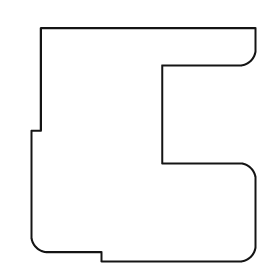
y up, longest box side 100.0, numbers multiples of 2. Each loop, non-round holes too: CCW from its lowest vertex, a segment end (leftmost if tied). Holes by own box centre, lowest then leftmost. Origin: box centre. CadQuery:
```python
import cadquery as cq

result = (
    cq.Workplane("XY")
    .moveTo(-18.0, -50.0)
    .lineTo(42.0, -50.0)
    .threePointArc((46.0, -48.0), (48.0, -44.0))
    .lineTo(48.0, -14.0)
    .threePointArc((46.0, -10.0), (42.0, -8.0))
    .lineTo(8.0, -8.0)
    .lineTo(8.0, 34.0)
    .lineTo(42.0, 34.0)
    .threePointArc((46.0, 36.0), (48.0, 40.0))
    .lineTo(48.0, 50.0)
    .lineTo(-44.0, 50.0)
    .lineTo(-44.0, 6.0)
    .lineTo(-48.0, 6.0)
    .lineTo(-48.0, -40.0)
    .threePointArc((-46.0, -44.0), (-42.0, -46.0))
    .lineTo(-18.0, -46.0)
    .close()
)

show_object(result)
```